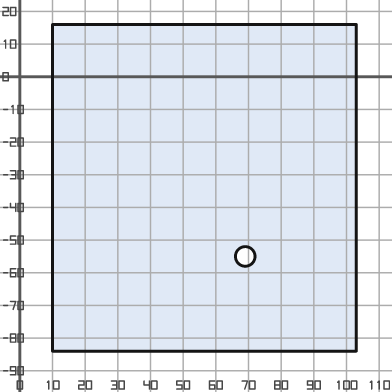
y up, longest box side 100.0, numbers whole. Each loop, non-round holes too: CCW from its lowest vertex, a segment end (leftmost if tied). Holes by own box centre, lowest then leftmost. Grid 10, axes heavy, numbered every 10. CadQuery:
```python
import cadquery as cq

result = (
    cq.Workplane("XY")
    .moveTo(10.0, -84.0)
    .lineTo(103.0, -84.0)
    .lineTo(103.0, 16.0)
    .lineTo(10.0, 16.0)
    .close()
    .moveTo(69.0, -55.0)
    .circle(3.0)
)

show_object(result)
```